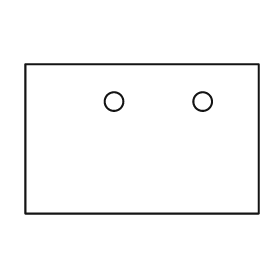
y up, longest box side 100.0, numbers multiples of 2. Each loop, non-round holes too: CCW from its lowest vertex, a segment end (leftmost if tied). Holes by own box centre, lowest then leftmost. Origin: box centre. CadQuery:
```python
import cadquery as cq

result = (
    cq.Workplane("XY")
    .moveTo(-50.0, -32.0)
    .lineTo(50.0, -32.0)
    .lineTo(50.0, 32.0)
    .lineTo(-50.0, 32.0)
    .close()
    .moveTo(-12.0, 16.0)
    .circle(4.0)
    .moveTo(26.0, 16.0)
    .circle(4.0)
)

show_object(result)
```